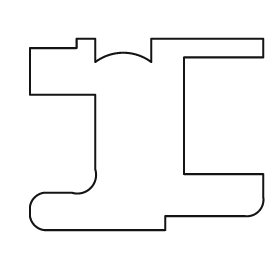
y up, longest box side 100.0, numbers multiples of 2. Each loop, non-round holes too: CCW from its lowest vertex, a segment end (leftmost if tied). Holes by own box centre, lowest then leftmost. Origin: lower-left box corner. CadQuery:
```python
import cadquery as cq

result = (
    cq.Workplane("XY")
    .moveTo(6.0, 0.0)
    .lineTo(58.0, 0.0)
    .lineTo(58.0, 6.0)
    .lineTo(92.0, 6.0)
    .threePointArc((98.0, 8.0), (100.0, 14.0))
    .lineTo(100.0, 24.0)
    .lineTo(66.0, 24.0)
    .lineTo(66.0, 74.0)
    .lineTo(100.0, 74.0)
    .lineTo(100.0, 82.0)
    .lineTo(52.0, 82.0)
    .lineTo(52.0, 72.0)
    .threePointArc((40.0, 76.0), (28.0, 72.0))
    .lineTo(28.0, 82.0)
    .lineTo(20.0, 82.0)
    .lineTo(20.0, 78.0)
    .lineTo(0.0, 78.0)
    .lineTo(0.0, 58.0)
    .lineTo(28.0, 58.0)
    .lineTo(28.0, 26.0)
    .threePointArc((26.0, 18.0), (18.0, 16.0))
    .lineTo(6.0, 16.0)
    .threePointArc((2.0, 14.0), (0.0, 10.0))
    .lineTo(0.0, 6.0)
    .threePointArc((2.0, 2.0), (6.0, 0.0))
    .close()
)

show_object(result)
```